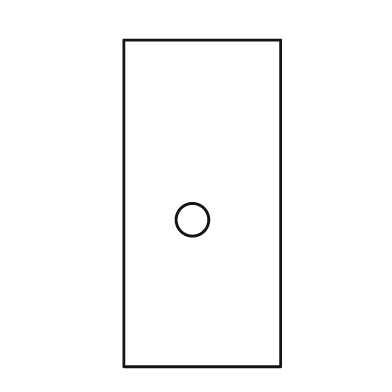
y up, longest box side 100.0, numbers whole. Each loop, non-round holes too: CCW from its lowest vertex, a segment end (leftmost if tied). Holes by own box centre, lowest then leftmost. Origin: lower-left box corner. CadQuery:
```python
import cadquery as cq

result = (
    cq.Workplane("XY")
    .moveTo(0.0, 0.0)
    .lineTo(48.0, 0.0)
    .lineTo(48.0, 100.0)
    .lineTo(0.0, 100.0)
    .close()
    .moveTo(21.0, 45.0)
    .circle(5.0)
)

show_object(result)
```